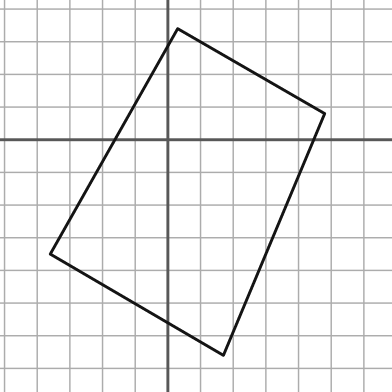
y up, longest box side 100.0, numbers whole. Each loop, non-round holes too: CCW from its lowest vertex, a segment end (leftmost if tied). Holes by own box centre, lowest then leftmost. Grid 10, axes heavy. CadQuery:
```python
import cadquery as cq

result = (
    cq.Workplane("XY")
    .moveTo(17.0, -66.0)
    .lineTo(48.0, 8.0)
    .lineTo(3.0, 34.0)
    .lineTo(-36.0, -35.0)
    .close()
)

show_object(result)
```